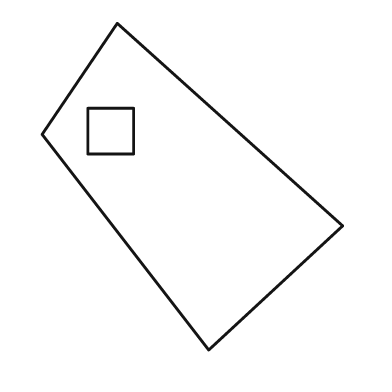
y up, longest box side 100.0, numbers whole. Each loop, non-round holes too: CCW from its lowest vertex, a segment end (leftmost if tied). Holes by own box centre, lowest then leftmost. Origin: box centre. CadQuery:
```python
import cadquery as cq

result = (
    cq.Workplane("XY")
    .moveTo(5.0, -50.0)
    .lineTo(46.0, -12.0)
    .lineTo(-23.0, 50.0)
    .lineTo(-46.0, 16.0)
    .close()
    .moveTo(-32.0, 10.0)
    .lineTo(-18.0, 10.0)
    .lineTo(-18.0, 24.0)
    .lineTo(-32.0, 24.0)
    .close()
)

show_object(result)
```